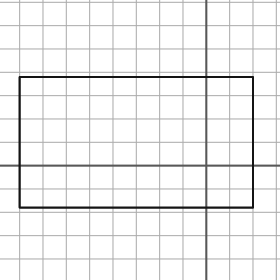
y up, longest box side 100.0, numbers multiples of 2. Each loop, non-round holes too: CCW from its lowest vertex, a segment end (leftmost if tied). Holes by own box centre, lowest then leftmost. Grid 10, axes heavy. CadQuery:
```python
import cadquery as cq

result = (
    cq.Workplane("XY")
    .moveTo(-80.0, -18.0)
    .lineTo(20.0, -18.0)
    .lineTo(20.0, 38.0)
    .lineTo(-80.0, 38.0)
    .close()
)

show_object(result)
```